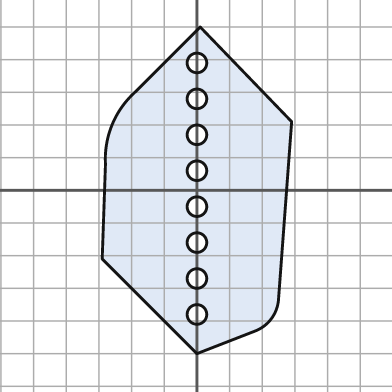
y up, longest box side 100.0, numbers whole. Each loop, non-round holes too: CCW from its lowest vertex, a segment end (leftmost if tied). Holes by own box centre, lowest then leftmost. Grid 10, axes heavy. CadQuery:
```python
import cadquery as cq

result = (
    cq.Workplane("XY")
    .moveTo(0.0, -50.0)
    .lineTo(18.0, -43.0)
    .threePointArc((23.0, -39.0), (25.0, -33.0))
    .lineTo(29.0, 21.0)
    .lineTo(1.0, 50.0)
    .lineTo(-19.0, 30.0)
    .threePointArc((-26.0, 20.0), (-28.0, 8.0))
    .lineTo(-29.0, -21.0)
    .close()
    .moveTo(0.0, -38.0)
    .circle(3.0)
    .moveTo(0.0, -27.0)
    .circle(3.0)
    .moveTo(0.0, -16.0)
    .circle(3.0)
    .moveTo(0.0, -5.0)
    .circle(3.0)
    .moveTo(0.0, 6.0)
    .circle(3.0)
    .moveTo(0.0, 17.0)
    .circle(3.0)
    .moveTo(0.0, 28.0)
    .circle(3.0)
    .moveTo(0.0, 39.0)
    .circle(3.0)
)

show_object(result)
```